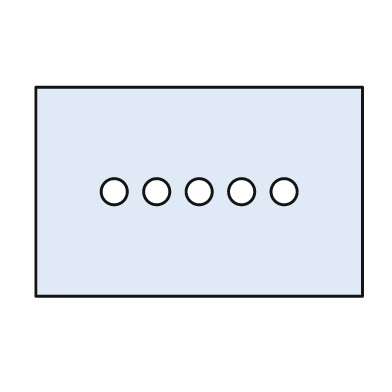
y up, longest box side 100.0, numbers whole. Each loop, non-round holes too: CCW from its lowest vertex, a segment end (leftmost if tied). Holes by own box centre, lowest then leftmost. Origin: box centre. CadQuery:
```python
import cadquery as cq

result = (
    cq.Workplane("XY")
    .moveTo(-50.0, -32.0)
    .lineTo(50.0, -32.0)
    .lineTo(50.0, 32.0)
    .lineTo(-50.0, 32.0)
    .close()
    .moveTo(-26.0, 0.0)
    .circle(4.0)
    .moveTo(-13.0, 0.0)
    .circle(4.0)
    .moveTo(0.0, 0.0)
    .circle(4.0)
    .moveTo(13.0, 0.0)
    .circle(4.0)
    .moveTo(26.0, 0.0)
    .circle(4.0)
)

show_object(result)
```